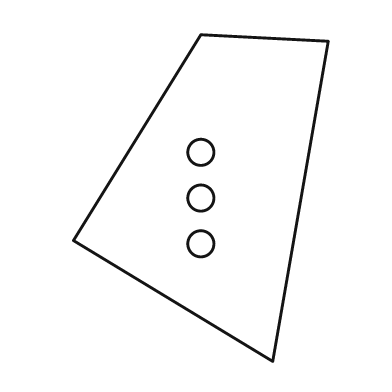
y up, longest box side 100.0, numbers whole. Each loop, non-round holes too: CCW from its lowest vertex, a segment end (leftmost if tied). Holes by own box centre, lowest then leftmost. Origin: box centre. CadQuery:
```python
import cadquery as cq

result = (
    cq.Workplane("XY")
    .moveTo(22.0, -50.0)
    .lineTo(39.0, 48.0)
    .lineTo(0.0, 50.0)
    .lineTo(-39.0, -13.0)
    .close()
    .moveTo(0.0, -14.0)
    .circle(4.0)
    .moveTo(0.0, 0.0)
    .circle(4.0)
    .moveTo(0.0, 14.0)
    .circle(4.0)
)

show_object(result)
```